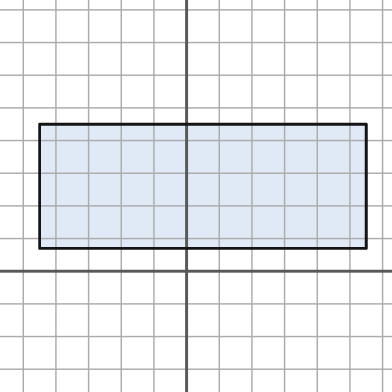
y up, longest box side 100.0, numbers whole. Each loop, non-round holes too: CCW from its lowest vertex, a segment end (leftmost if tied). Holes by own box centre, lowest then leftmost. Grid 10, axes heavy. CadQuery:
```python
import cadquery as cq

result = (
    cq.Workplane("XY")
    .moveTo(-45.0, 7.0)
    .lineTo(55.0, 7.0)
    .lineTo(55.0, 45.0)
    .lineTo(-45.0, 45.0)
    .close()
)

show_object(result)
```